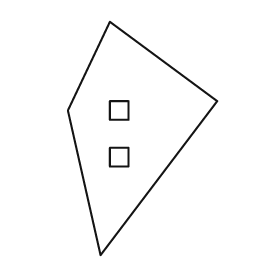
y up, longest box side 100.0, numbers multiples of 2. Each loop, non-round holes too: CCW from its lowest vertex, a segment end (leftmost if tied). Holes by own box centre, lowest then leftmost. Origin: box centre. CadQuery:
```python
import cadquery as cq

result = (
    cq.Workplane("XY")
    .moveTo(-18.0, -50.0)
    .lineTo(32.0, 16.0)
    .lineTo(-14.0, 50.0)
    .lineTo(-32.0, 12.0)
    .close()
    .moveTo(-14.0, -12.0)
    .lineTo(-6.0, -12.0)
    .lineTo(-6.0, -4.0)
    .lineTo(-14.0, -4.0)
    .close()
    .moveTo(-14.0, 8.0)
    .lineTo(-6.0, 8.0)
    .lineTo(-6.0, 16.0)
    .lineTo(-14.0, 16.0)
    .close()
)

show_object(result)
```